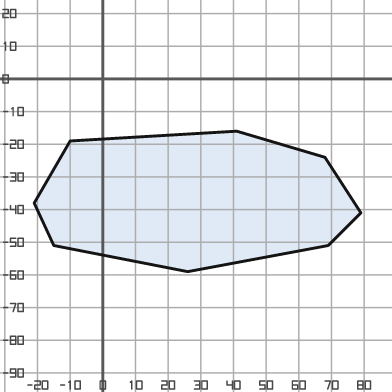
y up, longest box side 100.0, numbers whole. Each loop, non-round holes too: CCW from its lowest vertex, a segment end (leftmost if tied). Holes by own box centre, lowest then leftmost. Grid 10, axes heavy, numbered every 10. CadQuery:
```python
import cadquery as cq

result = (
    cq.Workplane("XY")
    .moveTo(26.0, -59.0)
    .lineTo(69.0, -51.0)
    .lineTo(79.0, -41.0)
    .lineTo(68.0, -24.0)
    .lineTo(41.0, -16.0)
    .lineTo(-10.0, -19.0)
    .lineTo(-21.0, -38.0)
    .lineTo(-15.0, -51.0)
    .close()
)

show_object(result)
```